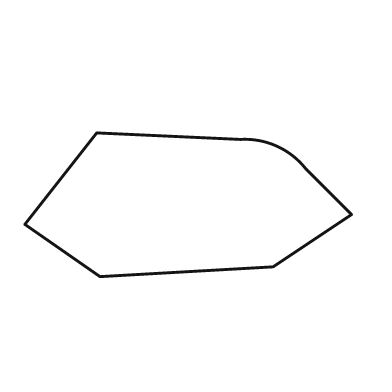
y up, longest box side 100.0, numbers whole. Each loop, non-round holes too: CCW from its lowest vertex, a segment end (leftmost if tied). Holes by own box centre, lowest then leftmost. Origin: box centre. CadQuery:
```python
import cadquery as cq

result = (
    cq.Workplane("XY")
    .moveTo(-27.0, -22.0)
    .lineTo(26.0, -19.0)
    .lineTo(50.0, -3.0)
    .lineTo(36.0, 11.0)
    .threePointArc((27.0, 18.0), (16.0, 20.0))
    .lineTo(-28.0, 22.0)
    .lineTo(-50.0, -6.0)
    .close()
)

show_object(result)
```